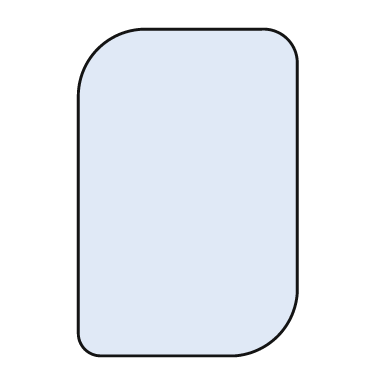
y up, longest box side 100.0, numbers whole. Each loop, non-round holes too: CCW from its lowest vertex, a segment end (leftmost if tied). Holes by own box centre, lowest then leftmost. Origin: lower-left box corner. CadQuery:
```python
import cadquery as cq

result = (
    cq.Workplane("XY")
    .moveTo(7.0, 0.0)
    .lineTo(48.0, 0.0)
    .threePointArc((61.0, 6.0), (67.0, 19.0))
    .lineTo(67.0, 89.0)
    .threePointArc((64.0, 97.0), (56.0, 100.0))
    .lineTo(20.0, 100.0)
    .threePointArc((6.0, 94.0), (0.0, 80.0))
    .lineTo(0.0, 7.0)
    .threePointArc((2.0, 2.0), (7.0, 0.0))
    .close()
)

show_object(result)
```